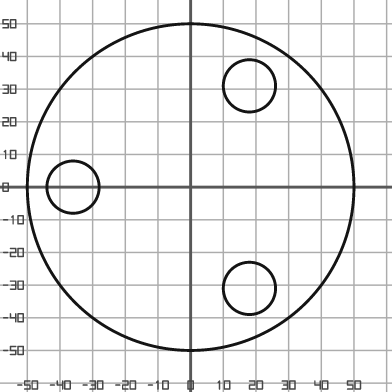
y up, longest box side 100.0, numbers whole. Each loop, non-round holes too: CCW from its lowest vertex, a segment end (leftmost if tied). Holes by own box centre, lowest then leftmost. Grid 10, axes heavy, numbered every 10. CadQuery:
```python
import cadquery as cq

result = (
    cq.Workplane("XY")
    .moveTo(0.0, 0.0)
    .circle(50.0)
    .moveTo(18.0, -31.0)
    .circle(8.0)
    .moveTo(-36.0, 0.0)
    .circle(8.0)
    .moveTo(18.0, 31.0)
    .circle(8.0)
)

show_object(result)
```